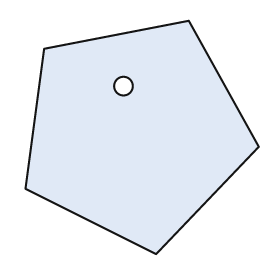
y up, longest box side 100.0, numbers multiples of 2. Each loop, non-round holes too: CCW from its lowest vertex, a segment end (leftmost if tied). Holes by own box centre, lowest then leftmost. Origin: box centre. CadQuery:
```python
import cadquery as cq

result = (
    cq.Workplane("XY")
    .moveTo(6.0, -50.0)
    .lineTo(50.0, -4.0)
    .lineTo(20.0, 50.0)
    .lineTo(-42.0, 38.0)
    .lineTo(-50.0, -22.0)
    .close()
    .moveTo(-8.0, 22.0)
    .circle(4.0)
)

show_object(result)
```